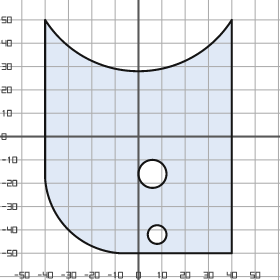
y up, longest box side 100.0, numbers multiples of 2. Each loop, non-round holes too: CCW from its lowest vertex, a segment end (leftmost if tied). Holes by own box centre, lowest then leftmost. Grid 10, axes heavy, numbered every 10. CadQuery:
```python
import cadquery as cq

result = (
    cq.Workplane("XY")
    .moveTo(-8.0, -50.0)
    .lineTo(40.0, -50.0)
    .lineTo(40.0, 50.0)
    .threePointArc((0.0, 28.0), (-40.0, 50.0))
    .lineTo(-40.0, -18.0)
    .threePointArc((-30.0, -40.0), (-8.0, -50.0))
    .close()
    .moveTo(8.0, -42.0)
    .circle(4.0)
    .moveTo(6.0, -16.0)
    .circle(6.0)
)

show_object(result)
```